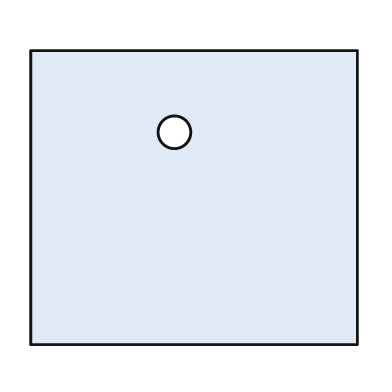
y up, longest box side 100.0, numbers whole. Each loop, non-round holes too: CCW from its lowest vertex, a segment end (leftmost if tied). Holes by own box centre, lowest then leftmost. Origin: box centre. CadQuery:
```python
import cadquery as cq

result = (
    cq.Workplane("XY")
    .moveTo(-50.0, -45.0)
    .lineTo(50.0, -45.0)
    .lineTo(50.0, 45.0)
    .lineTo(-50.0, 45.0)
    .close()
    .moveTo(-6.0, 20.0)
    .circle(5.0)
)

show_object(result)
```